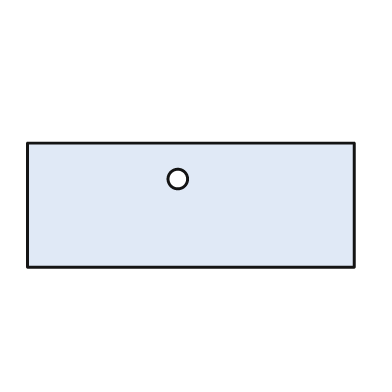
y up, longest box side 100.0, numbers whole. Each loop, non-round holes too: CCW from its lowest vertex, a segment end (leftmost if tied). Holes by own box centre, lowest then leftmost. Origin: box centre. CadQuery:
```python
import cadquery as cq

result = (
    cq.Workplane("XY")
    .moveTo(-50.0, -19.0)
    .lineTo(50.0, -19.0)
    .lineTo(50.0, 19.0)
    .lineTo(-50.0, 19.0)
    .close()
    .moveTo(-4.0, 8.0)
    .circle(3.0)
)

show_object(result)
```